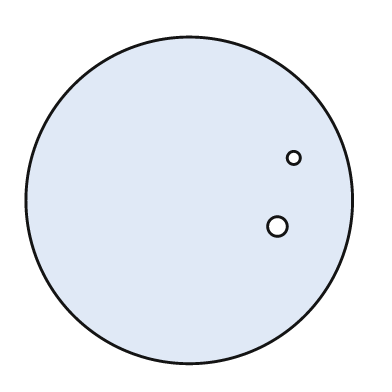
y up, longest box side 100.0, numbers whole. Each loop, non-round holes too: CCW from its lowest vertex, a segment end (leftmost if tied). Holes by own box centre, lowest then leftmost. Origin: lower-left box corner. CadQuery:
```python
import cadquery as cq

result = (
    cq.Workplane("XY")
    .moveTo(50.0, 50.0)
    .circle(50.0)
    .moveTo(77.0, 42.0)
    .circle(3.0)
    .moveTo(82.0, 63.0)
    .circle(2.0)
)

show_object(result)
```